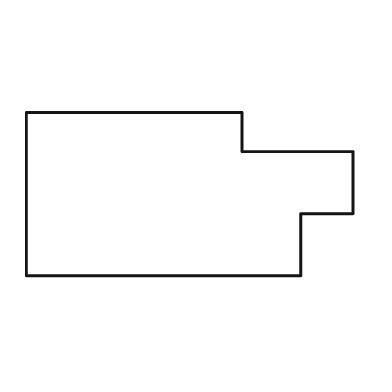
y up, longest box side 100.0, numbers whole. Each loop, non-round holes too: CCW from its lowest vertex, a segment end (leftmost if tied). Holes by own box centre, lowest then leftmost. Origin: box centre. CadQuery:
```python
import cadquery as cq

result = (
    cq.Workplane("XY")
    .moveTo(-50.0, -25.0)
    .lineTo(34.0, -25.0)
    .lineTo(34.0, -6.0)
    .lineTo(50.0, -6.0)
    .lineTo(50.0, 13.0)
    .lineTo(16.0, 13.0)
    .lineTo(16.0, 25.0)
    .lineTo(-50.0, 25.0)
    .close()
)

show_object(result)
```